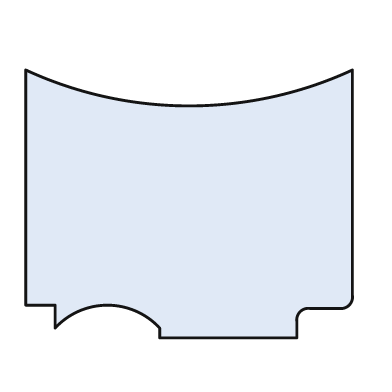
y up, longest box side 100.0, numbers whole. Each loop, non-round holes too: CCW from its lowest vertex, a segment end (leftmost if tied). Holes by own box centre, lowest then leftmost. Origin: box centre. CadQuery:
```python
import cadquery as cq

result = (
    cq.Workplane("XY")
    .moveTo(-9.0, -41.0)
    .lineTo(33.0, -41.0)
    .lineTo(33.0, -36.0)
    .threePointArc((34.0, -33.0), (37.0, -32.0))
    .lineTo(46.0, -32.0)
    .threePointArc((49.0, -31.0), (50.0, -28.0))
    .lineTo(50.0, 41.0)
    .threePointArc((0.0, 30.0), (-50.0, 41.0))
    .lineTo(-50.0, -31.0)
    .lineTo(-41.0, -31.0)
    .lineTo(-41.0, -38.0)
    .threePointArc((-25.0, -31.0), (-9.0, -38.0))
    .close()
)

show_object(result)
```